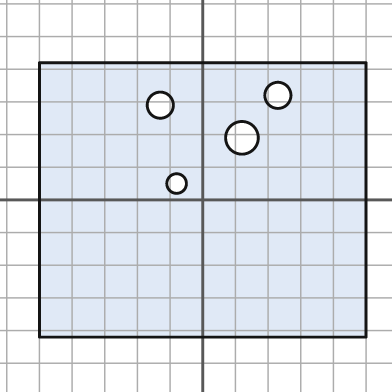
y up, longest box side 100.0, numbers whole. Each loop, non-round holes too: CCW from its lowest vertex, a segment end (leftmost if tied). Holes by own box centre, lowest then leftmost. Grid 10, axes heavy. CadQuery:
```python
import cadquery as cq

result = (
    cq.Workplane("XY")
    .moveTo(-50.0, -42.0)
    .lineTo(50.0, -42.0)
    .lineTo(50.0, 42.0)
    .lineTo(-50.0, 42.0)
    .close()
    .moveTo(-8.0, 5.0)
    .circle(3.0)
    .moveTo(12.0, 19.0)
    .circle(5.0)
    .moveTo(-13.0, 29.0)
    .circle(4.0)
    .moveTo(23.0, 32.0)
    .circle(4.0)
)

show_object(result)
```